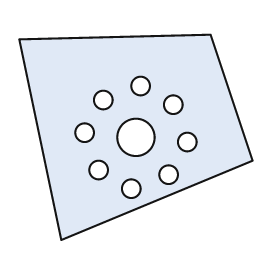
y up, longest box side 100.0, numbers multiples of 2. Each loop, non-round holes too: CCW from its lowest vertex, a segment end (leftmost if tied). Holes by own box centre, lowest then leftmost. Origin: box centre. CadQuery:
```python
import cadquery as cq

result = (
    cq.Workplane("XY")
    .moveTo(-32.0, -44.0)
    .lineTo(50.0, -10.0)
    .lineTo(32.0, 44.0)
    .lineTo(-50.0, 42.0)
    .close()
    .moveTo(-2.0, -22.0)
    .circle(4.0)
    .moveTo(14.0, -16.0)
    .circle(4.0)
    .moveTo(-16.0, -14.0)
    .circle(4.0)
    .moveTo(22.0, -2.0)
    .circle(4.0)
    .moveTo(0.0, 0.0)
    .circle(8.0)
    .moveTo(-22.0, 2.0)
    .circle(4.0)
    .moveTo(16.0, 14.0)
    .circle(4.0)
    .moveTo(-14.0, 16.0)
    .circle(4.0)
    .moveTo(2.0, 22.0)
    .circle(4.0)
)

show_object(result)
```